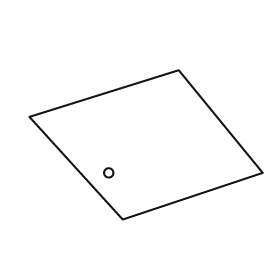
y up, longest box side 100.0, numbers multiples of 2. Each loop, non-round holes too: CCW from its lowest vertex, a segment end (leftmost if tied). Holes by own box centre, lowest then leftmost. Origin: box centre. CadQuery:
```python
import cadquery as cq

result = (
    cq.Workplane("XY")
    .moveTo(-10.0, -32.0)
    .lineTo(50.0, -12.0)
    .lineTo(14.0, 32.0)
    .lineTo(-50.0, 12.0)
    .close()
    .moveTo(-16.0, -12.0)
    .circle(2.0)
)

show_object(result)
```